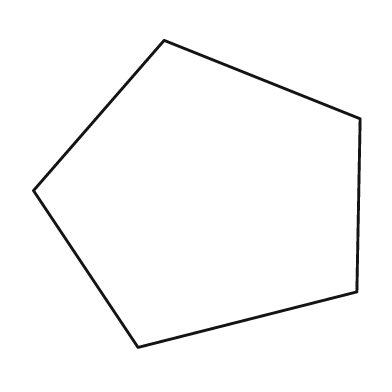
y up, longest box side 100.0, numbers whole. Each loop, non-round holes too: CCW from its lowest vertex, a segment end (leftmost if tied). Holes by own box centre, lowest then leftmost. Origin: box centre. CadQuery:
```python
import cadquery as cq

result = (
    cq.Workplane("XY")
    .moveTo(-18.0, -47.0)
    .lineTo(49.0, -30.0)
    .lineTo(50.0, 23.0)
    .lineTo(-10.0, 47.0)
    .lineTo(-50.0, 1.0)
    .close()
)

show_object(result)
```